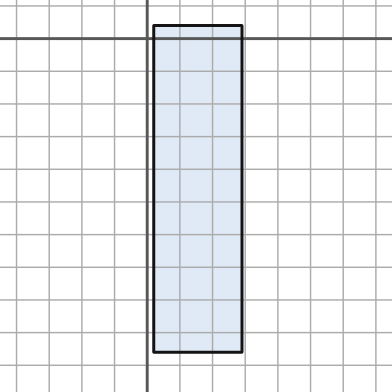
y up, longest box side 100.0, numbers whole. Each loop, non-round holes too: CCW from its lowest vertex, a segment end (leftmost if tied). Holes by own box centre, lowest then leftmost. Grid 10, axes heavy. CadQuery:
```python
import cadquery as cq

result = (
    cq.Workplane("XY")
    .moveTo(2.0, -96.0)
    .lineTo(29.0, -96.0)
    .lineTo(29.0, 4.0)
    .lineTo(2.0, 4.0)
    .close()
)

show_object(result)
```